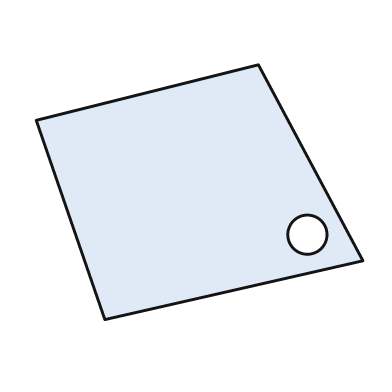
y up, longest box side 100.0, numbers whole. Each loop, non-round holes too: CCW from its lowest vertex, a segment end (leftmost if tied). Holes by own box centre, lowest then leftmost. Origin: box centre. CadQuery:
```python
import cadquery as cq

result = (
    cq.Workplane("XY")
    .moveTo(-29.0, -39.0)
    .lineTo(50.0, -21.0)
    .lineTo(18.0, 39.0)
    .lineTo(-50.0, 22.0)
    .close()
    .moveTo(33.0, -13.0)
    .circle(6.0)
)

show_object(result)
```